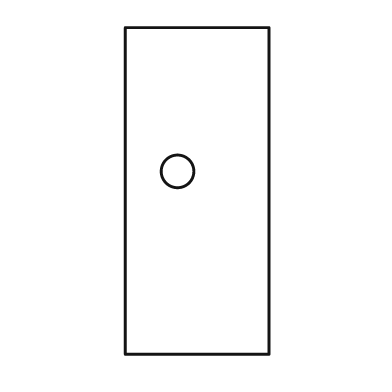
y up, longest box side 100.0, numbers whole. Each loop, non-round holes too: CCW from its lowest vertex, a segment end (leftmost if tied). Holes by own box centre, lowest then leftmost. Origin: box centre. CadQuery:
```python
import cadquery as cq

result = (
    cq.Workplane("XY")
    .moveTo(-22.0, -50.0)
    .lineTo(22.0, -50.0)
    .lineTo(22.0, 50.0)
    .lineTo(-22.0, 50.0)
    .close()
    .moveTo(-6.0, 6.0)
    .circle(5.0)
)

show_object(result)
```